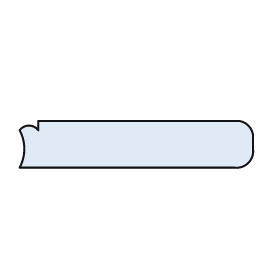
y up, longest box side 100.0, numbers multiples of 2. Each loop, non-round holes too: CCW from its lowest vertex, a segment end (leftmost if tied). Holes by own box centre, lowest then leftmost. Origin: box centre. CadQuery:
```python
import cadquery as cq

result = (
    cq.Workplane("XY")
    .moveTo(-50.0, -10.0)
    .lineTo(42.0, -10.0)
    .threePointArc((48.0, -8.0), (50.0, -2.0))
    .lineTo(50.0, 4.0)
    .threePointArc((48.0, 8.0), (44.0, 10.0))
    .lineTo(-42.0, 10.0)
    .lineTo(-42.0, 6.0)
    .threePointArc((-46.0, 8.0), (-50.0, 6.0))
    .threePointArc((-48.0, -2.0), (-50.0, -10.0))
    .close()
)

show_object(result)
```